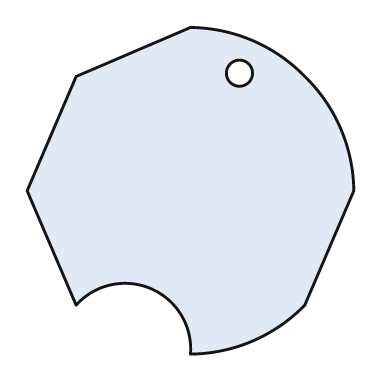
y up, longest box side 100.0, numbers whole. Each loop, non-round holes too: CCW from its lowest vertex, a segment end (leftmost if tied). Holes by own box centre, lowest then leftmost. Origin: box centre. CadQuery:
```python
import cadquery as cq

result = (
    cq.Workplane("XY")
    .moveTo(0.0, -50.0)
    .threePointArc((19.0, -46.0), (35.0, -35.0))
    .lineTo(50.0, 0.0)
    .threePointArc((46.0, 19.0), (35.0, 35.0))
    .threePointArc((19.0, 46.0), (0.0, 50.0))
    .lineTo(-35.0, 35.0)
    .lineTo(-50.0, 0.0)
    .lineTo(-35.0, -35.0)
    .threePointArc((-12.0, -30.0), (0.0, -50.0))
    .close()
    .moveTo(15.0, 36.0)
    .circle(4.0)
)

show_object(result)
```